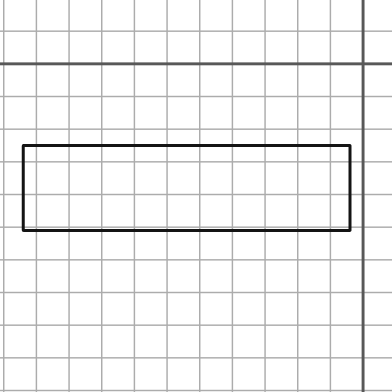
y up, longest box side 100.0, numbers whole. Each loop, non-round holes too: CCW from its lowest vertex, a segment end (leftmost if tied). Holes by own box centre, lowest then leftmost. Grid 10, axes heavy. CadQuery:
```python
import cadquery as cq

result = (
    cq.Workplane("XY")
    .moveTo(-104.0, -51.0)
    .lineTo(-4.0, -51.0)
    .lineTo(-4.0, -25.0)
    .lineTo(-104.0, -25.0)
    .close()
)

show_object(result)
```